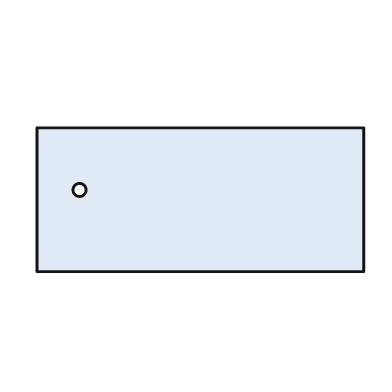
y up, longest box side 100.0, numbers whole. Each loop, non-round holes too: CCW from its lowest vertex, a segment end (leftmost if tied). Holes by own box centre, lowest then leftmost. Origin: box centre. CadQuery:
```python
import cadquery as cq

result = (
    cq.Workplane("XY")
    .moveTo(-50.0, -22.0)
    .lineTo(50.0, -22.0)
    .lineTo(50.0, 22.0)
    .lineTo(-50.0, 22.0)
    .close()
    .moveTo(-37.0, 3.0)
    .circle(2.0)
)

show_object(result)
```